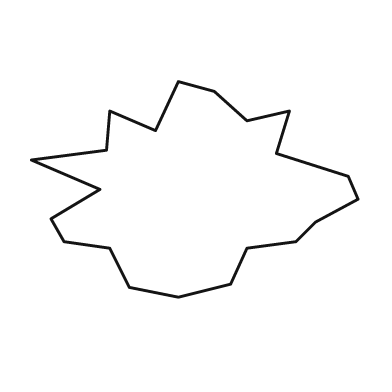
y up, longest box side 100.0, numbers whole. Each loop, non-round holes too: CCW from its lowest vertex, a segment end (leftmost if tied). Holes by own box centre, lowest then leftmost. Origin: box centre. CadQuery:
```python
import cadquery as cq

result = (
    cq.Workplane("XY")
    .moveTo(-5.0, -33.0)
    .lineTo(11.0, -29.0)
    .lineTo(16.0, -18.0)
    .lineTo(31.0, -16.0)
    .lineTo(37.0, -10.0)
    .lineTo(50.0, -3.0)
    .lineTo(47.0, 4.0)
    .lineTo(25.0, 11.0)
    .lineTo(29.0, 24.0)
    .lineTo(16.0, 21.0)
    .lineTo(6.0, 30.0)
    .lineTo(-5.0, 33.0)
    .lineTo(-12.0, 18.0)
    .lineTo(-26.0, 24.0)
    .lineTo(-27.0, 12.0)
    .lineTo(-50.0, 9.0)
    .lineTo(-29.0, 0.0)
    .lineTo(-44.0, -9.0)
    .lineTo(-40.0, -16.0)
    .lineTo(-26.0, -18.0)
    .lineTo(-20.0, -30.0)
    .close()
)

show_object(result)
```